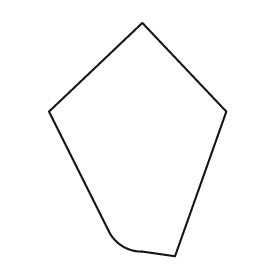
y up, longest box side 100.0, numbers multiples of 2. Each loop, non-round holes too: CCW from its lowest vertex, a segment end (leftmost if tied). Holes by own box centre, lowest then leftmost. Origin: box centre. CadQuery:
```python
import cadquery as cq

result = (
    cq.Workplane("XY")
    .moveTo(16.0, -50.0)
    .lineTo(38.0, 12.0)
    .lineTo(2.0, 50.0)
    .lineTo(-38.0, 12.0)
    .lineTo(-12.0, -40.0)
    .threePointArc((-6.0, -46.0), (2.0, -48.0))
    .close()
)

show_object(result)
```